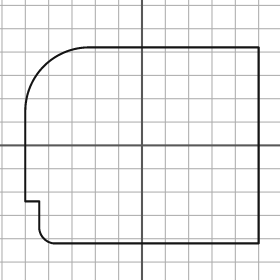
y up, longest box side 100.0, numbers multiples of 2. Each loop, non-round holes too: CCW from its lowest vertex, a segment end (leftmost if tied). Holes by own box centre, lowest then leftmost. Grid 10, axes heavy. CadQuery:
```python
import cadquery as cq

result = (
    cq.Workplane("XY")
    .moveTo(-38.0, -42.0)
    .lineTo(50.0, -42.0)
    .lineTo(50.0, 42.0)
    .lineTo(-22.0, 42.0)
    .threePointArc((-42.0, 34.0), (-50.0, 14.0))
    .lineTo(-50.0, -24.0)
    .lineTo(-44.0, -24.0)
    .lineTo(-44.0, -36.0)
    .threePointArc((-42.0, -40.0), (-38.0, -42.0))
    .close()
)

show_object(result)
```